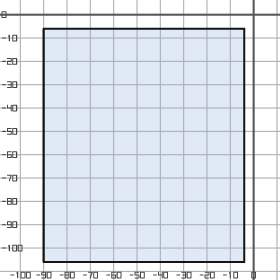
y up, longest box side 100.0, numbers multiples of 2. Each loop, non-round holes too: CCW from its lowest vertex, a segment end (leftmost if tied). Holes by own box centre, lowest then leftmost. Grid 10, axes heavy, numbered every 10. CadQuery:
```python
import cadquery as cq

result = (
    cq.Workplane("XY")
    .moveTo(-90.0, -106.0)
    .lineTo(-4.0, -106.0)
    .lineTo(-4.0, -6.0)
    .lineTo(-90.0, -6.0)
    .close()
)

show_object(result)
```